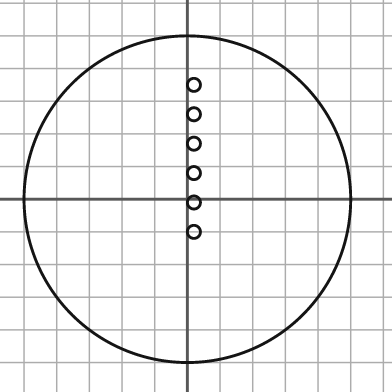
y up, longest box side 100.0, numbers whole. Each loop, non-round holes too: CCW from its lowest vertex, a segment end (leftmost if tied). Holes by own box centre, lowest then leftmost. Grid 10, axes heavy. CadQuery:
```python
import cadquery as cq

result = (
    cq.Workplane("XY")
    .moveTo(0.0, 0.0)
    .circle(50.0)
    .moveTo(2.0, -10.0)
    .circle(2.0)
    .moveTo(2.0, -1.0)
    .circle(2.0)
    .moveTo(2.0, 8.0)
    .circle(2.0)
    .moveTo(2.0, 17.0)
    .circle(2.0)
    .moveTo(2.0, 26.0)
    .circle(2.0)
    .moveTo(2.0, 35.0)
    .circle(2.0)
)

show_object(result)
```